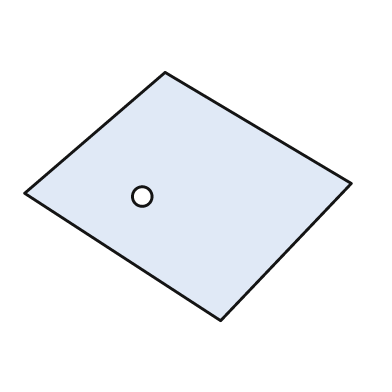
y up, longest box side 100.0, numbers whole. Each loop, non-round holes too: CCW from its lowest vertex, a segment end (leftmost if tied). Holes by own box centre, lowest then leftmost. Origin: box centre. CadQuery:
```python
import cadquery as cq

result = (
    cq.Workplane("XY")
    .moveTo(10.0, -38.0)
    .lineTo(50.0, 4.0)
    .lineTo(-7.0, 38.0)
    .lineTo(-50.0, 1.0)
    .close()
    .moveTo(-14.0, 0.0)
    .circle(3.0)
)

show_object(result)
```